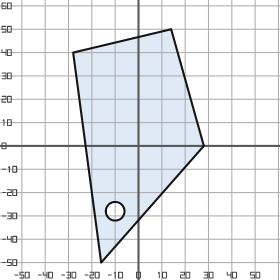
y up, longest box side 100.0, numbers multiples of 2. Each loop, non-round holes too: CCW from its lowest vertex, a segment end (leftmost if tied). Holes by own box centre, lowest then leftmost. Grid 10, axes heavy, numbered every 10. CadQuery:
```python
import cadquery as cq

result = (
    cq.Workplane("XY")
    .moveTo(-16.0, -50.0)
    .lineTo(28.0, 0.0)
    .lineTo(14.0, 50.0)
    .lineTo(-28.0, 40.0)
    .close()
    .moveTo(-10.0, -28.0)
    .circle(4.0)
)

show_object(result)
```